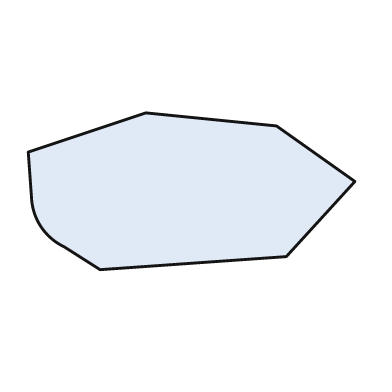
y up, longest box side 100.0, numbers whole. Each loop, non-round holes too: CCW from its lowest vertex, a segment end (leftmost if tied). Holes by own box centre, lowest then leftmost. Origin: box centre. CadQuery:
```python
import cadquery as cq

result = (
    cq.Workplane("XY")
    .moveTo(-28.0, -24.0)
    .lineTo(29.0, -20.0)
    .lineTo(50.0, 3.0)
    .lineTo(26.0, 20.0)
    .lineTo(-14.0, 24.0)
    .lineTo(-50.0, 12.0)
    .lineTo(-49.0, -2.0)
    .threePointArc((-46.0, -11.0), (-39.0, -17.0))
    .close()
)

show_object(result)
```